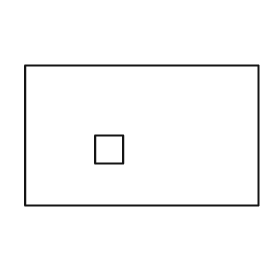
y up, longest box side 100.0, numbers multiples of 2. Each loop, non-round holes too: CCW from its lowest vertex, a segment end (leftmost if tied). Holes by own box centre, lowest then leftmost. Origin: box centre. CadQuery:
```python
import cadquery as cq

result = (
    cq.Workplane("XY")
    .moveTo(-50.0, -30.0)
    .lineTo(50.0, -30.0)
    .lineTo(50.0, 30.0)
    .lineTo(-50.0, 30.0)
    .close()
    .moveTo(-20.0, -12.0)
    .lineTo(-8.0, -12.0)
    .lineTo(-8.0, 0.0)
    .lineTo(-20.0, 0.0)
    .close()
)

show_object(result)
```